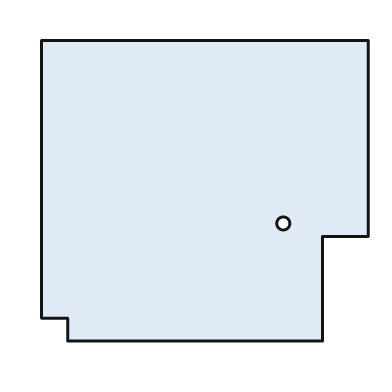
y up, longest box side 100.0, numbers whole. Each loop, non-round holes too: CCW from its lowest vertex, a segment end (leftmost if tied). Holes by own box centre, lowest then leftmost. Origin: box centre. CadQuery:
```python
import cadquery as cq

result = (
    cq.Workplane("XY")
    .moveTo(-42.0, -46.0)
    .lineTo(36.0, -46.0)
    .lineTo(36.0, -14.0)
    .lineTo(50.0, -14.0)
    .lineTo(50.0, 46.0)
    .lineTo(-50.0, 46.0)
    .lineTo(-50.0, -39.0)
    .lineTo(-42.0, -39.0)
    .close()
    .moveTo(24.0, -10.0)
    .circle(2.0)
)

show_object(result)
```